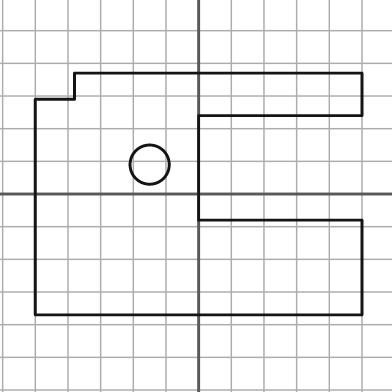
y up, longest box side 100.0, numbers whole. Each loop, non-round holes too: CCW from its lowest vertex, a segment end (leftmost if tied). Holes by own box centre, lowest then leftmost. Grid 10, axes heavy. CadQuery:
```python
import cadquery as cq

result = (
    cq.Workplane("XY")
    .moveTo(-50.0, -37.0)
    .lineTo(50.0, -37.0)
    .lineTo(50.0, -8.0)
    .lineTo(0.0, -8.0)
    .lineTo(0.0, 24.0)
    .lineTo(50.0, 24.0)
    .lineTo(50.0, 37.0)
    .lineTo(-38.0, 37.0)
    .lineTo(-38.0, 29.0)
    .lineTo(-50.0, 29.0)
    .close()
    .moveTo(-15.0, 9.0)
    .circle(6.0)
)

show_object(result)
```